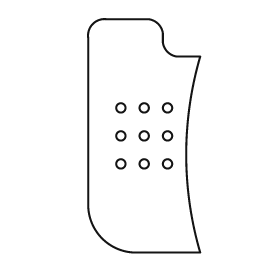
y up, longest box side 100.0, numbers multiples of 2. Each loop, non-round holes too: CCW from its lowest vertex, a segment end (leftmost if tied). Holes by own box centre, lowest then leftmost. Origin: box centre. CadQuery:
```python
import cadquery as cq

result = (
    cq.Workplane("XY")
    .moveTo(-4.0, -50.0)
    .lineTo(24.0, -50.0)
    .threePointArc((18.0, -8.0), (24.0, 34.0))
    .lineTo(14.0, 34.0)
    .threePointArc((10.0, 36.0), (8.0, 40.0))
    .lineTo(8.0, 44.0)
    .threePointArc((6.0, 48.0), (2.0, 50.0))
    .lineTo(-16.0, 50.0)
    .threePointArc((-22.0, 48.0), (-24.0, 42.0))
    .lineTo(-24.0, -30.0)
    .threePointArc((-18.0, -44.0), (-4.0, -50.0))
    .close()
    .moveTo(-10.0, -12.0)
    .circle(2.0)
    .moveTo(0.0, -12.0)
    .circle(2.0)
    .moveTo(10.0, -12.0)
    .circle(2.0)
    .moveTo(-10.0, 0.0)
    .circle(2.0)
    .moveTo(0.0, 0.0)
    .circle(2.0)
    .moveTo(10.0, 0.0)
    .circle(2.0)
    .moveTo(-10.0, 12.0)
    .circle(2.0)
    .moveTo(0.0, 12.0)
    .circle(2.0)
    .moveTo(10.0, 12.0)
    .circle(2.0)
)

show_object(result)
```